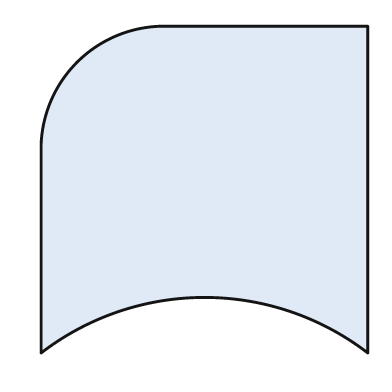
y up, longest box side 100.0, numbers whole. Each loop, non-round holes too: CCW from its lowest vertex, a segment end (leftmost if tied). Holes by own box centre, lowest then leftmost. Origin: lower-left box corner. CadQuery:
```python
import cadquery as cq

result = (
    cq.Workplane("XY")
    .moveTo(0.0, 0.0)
    .threePointArc((50.0, 17.0), (100.0, 0.0))
    .lineTo(100.0, 100.0)
    .lineTo(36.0, 100.0)
    .threePointArc((11.0, 89.0), (0.0, 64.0))
    .close()
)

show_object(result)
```